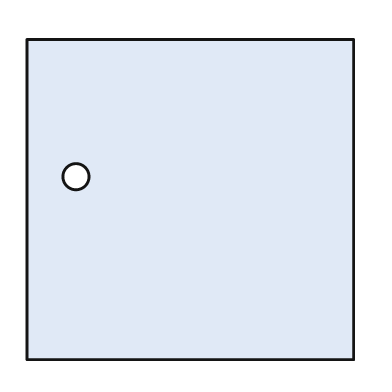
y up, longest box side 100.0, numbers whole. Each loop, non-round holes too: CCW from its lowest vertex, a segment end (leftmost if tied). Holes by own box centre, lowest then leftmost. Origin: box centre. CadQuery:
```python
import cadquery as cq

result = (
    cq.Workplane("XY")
    .moveTo(-50.0, -49.0)
    .lineTo(50.0, -49.0)
    .lineTo(50.0, 49.0)
    .lineTo(-50.0, 49.0)
    .close()
    .moveTo(-35.0, 7.0)
    .circle(4.0)
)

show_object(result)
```